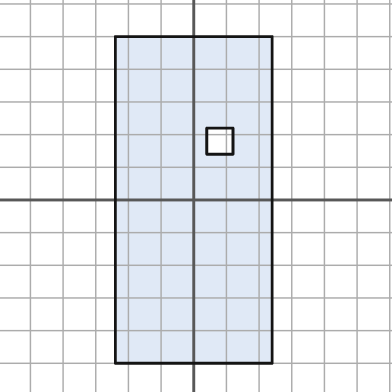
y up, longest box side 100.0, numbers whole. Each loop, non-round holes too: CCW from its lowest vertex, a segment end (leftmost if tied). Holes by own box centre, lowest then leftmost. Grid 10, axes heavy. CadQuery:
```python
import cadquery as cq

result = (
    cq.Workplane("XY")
    .moveTo(-24.0, -50.0)
    .lineTo(24.0, -50.0)
    .lineTo(24.0, 50.0)
    .lineTo(-24.0, 50.0)
    .close()
    .moveTo(4.0, 14.0)
    .lineTo(12.0, 14.0)
    .lineTo(12.0, 22.0)
    .lineTo(4.0, 22.0)
    .close()
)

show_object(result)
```